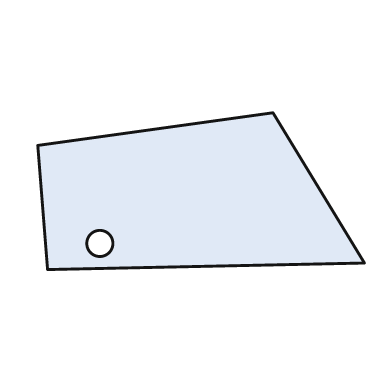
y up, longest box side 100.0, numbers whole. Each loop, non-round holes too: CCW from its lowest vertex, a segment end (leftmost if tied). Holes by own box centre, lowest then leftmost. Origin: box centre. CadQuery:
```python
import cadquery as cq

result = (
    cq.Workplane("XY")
    .moveTo(-47.0, -24.0)
    .lineTo(50.0, -22.0)
    .lineTo(22.0, 24.0)
    .lineTo(-50.0, 14.0)
    .close()
    .moveTo(-31.0, -16.0)
    .circle(4.0)
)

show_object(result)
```